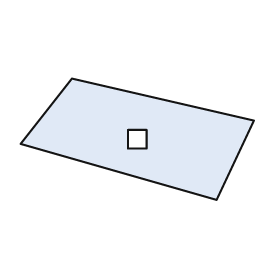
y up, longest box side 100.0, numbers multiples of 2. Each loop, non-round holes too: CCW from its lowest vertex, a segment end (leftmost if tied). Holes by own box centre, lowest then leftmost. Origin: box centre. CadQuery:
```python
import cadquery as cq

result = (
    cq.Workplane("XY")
    .moveTo(34.0, -26.0)
    .lineTo(50.0, 8.0)
    .lineTo(-28.0, 26.0)
    .lineTo(-50.0, -2.0)
    .close()
    .moveTo(-4.0, -4.0)
    .lineTo(4.0, -4.0)
    .lineTo(4.0, 4.0)
    .lineTo(-4.0, 4.0)
    .close()
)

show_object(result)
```